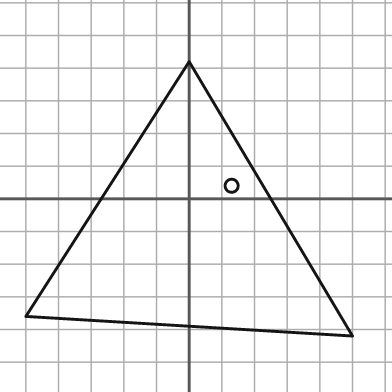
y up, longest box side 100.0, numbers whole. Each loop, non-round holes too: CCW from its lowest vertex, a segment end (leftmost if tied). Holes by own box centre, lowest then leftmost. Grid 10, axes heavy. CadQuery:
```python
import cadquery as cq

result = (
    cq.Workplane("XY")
    .moveTo(50.0, -42.0)
    .lineTo(0.0, 42.0)
    .lineTo(-50.0, -36.0)
    .close()
    .moveTo(13.0, 4.0)
    .circle(2.0)
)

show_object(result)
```